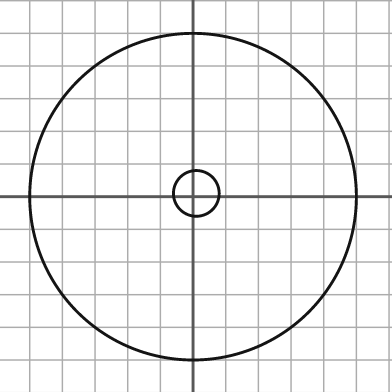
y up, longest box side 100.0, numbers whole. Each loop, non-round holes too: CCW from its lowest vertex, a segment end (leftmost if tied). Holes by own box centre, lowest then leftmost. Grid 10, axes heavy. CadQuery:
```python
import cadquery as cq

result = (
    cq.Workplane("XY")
    .moveTo(0.0, 0.0)
    .circle(50.0)
    .moveTo(1.0, 1.0)
    .circle(7.0)
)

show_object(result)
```